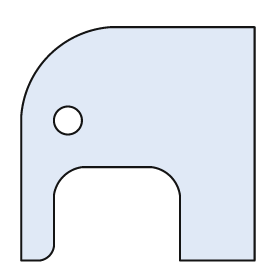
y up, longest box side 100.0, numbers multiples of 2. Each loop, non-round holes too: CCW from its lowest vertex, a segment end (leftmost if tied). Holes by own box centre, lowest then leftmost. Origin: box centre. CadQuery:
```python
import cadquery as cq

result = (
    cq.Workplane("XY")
    .moveTo(-50.0, -50.0)
    .lineTo(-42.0, -50.0)
    .threePointArc((-38.0, -48.0), (-36.0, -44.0))
    .lineTo(-36.0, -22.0)
    .threePointArc((-32.0, -14.0), (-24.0, -10.0))
    .lineTo(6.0, -10.0)
    .threePointArc((14.0, -14.0), (18.0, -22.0))
    .lineTo(18.0, -50.0)
    .lineTo(50.0, -50.0)
    .lineTo(50.0, 50.0)
    .lineTo(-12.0, 50.0)
    .threePointArc((-38.0, 38.0), (-50.0, 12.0))
    .close()
    .moveTo(-30.0, 10.0)
    .circle(6.0)
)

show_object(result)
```